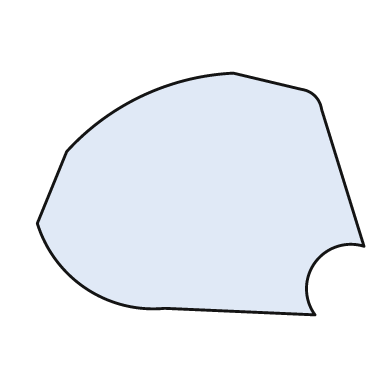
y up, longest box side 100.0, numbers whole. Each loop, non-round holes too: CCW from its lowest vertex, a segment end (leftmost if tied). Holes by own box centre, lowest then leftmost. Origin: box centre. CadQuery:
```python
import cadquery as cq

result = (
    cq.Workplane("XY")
    .moveTo(35.0, -37.0)
    .threePointArc((35.0, -21.0), (50.0, -16.0))
    .lineTo(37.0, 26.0)
    .threePointArc((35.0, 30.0), (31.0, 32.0))
    .lineTo(10.0, 37.0)
    .threePointArc((-18.0, 30.0), (-41.0, 13.0))
    .lineTo(-50.0, -9.0)
    .threePointArc((-35.0, -29.0), (-11.0, -35.0))
    .close()
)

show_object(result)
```